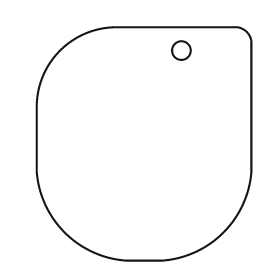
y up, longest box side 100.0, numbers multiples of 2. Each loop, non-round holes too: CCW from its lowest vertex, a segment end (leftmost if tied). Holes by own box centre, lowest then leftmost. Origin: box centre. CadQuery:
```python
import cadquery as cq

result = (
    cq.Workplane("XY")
    .moveTo(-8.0, -50.0)
    .lineTo(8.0, -50.0)
    .threePointArc((34.0, -38.0), (46.0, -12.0))
    .lineTo(46.0, 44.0)
    .threePointArc((44.0, 48.0), (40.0, 50.0))
    .lineTo(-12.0, 50.0)
    .threePointArc((-36.0, 40.0), (-46.0, 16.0))
    .lineTo(-46.0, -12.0)
    .threePointArc((-34.0, -38.0), (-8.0, -50.0))
    .close()
    .moveTo(16.0, 40.0)
    .circle(4.0)
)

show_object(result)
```